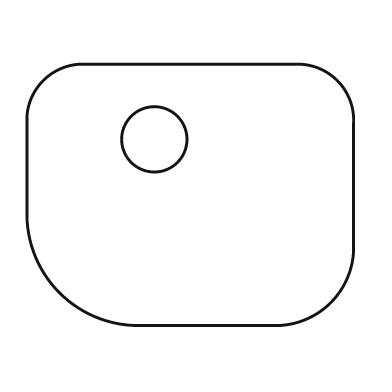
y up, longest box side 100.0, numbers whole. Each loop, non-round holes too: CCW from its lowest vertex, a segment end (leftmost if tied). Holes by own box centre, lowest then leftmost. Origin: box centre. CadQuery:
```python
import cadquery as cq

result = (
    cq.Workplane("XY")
    .moveTo(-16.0, -40.0)
    .lineTo(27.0, -40.0)
    .threePointArc((43.0, -33.0), (50.0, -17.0))
    .lineTo(50.0, 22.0)
    .threePointArc((45.0, 35.0), (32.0, 40.0))
    .lineTo(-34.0, 40.0)
    .threePointArc((-45.0, 35.0), (-50.0, 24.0))
    .lineTo(-50.0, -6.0)
    .threePointArc((-40.0, -30.0), (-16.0, -40.0))
    .close()
    .moveTo(-11.0, 17.0)
    .circle(10.0)
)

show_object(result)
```